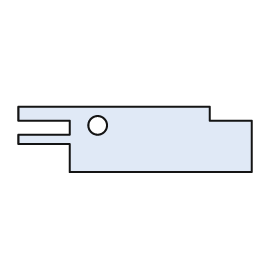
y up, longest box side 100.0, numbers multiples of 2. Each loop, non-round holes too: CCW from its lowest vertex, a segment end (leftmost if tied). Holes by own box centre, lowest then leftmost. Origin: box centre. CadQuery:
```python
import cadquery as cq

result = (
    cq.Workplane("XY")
    .moveTo(-28.0, -14.0)
    .lineTo(50.0, -14.0)
    .lineTo(50.0, 8.0)
    .lineTo(32.0, 8.0)
    .lineTo(32.0, 14.0)
    .lineTo(-50.0, 14.0)
    .lineTo(-50.0, 8.0)
    .lineTo(-28.0, 8.0)
    .lineTo(-28.0, 2.0)
    .lineTo(-50.0, 2.0)
    .lineTo(-50.0, -2.0)
    .lineTo(-28.0, -2.0)
    .close()
    .moveTo(-16.0, 6.0)
    .circle(4.0)
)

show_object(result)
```